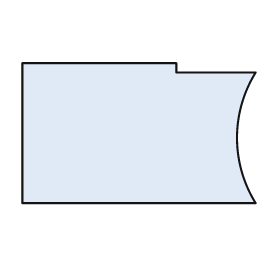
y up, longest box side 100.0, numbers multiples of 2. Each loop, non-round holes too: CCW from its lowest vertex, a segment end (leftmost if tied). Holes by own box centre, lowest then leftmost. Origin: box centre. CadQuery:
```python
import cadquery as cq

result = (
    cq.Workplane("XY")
    .moveTo(-50.0, -30.0)
    .lineTo(50.0, -30.0)
    .threePointArc((42.0, -2.0), (50.0, 26.0))
    .lineTo(16.0, 26.0)
    .lineTo(16.0, 30.0)
    .lineTo(-50.0, 30.0)
    .close()
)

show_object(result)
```